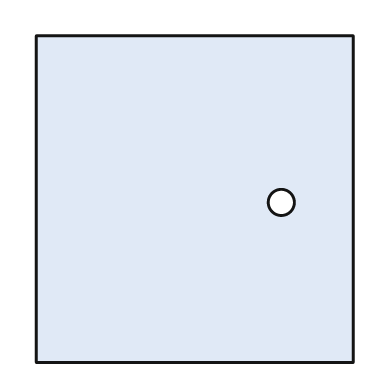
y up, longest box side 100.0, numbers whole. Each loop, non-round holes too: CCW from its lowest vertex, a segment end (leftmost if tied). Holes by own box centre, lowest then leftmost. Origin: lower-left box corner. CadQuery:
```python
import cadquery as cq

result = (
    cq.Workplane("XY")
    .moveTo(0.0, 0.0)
    .lineTo(97.0, 0.0)
    .lineTo(97.0, 100.0)
    .lineTo(0.0, 100.0)
    .close()
    .moveTo(75.0, 49.0)
    .circle(4.0)
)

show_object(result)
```